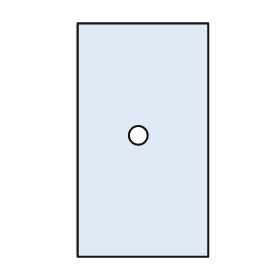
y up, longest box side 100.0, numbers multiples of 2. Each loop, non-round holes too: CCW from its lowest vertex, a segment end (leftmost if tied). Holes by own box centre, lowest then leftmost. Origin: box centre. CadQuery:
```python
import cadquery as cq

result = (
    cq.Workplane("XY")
    .moveTo(-28.0, -50.0)
    .lineTo(28.0, -50.0)
    .lineTo(28.0, 50.0)
    .lineTo(-28.0, 50.0)
    .close()
    .moveTo(-2.0, 2.0)
    .circle(4.0)
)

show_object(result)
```